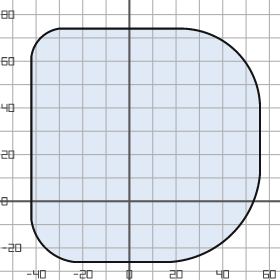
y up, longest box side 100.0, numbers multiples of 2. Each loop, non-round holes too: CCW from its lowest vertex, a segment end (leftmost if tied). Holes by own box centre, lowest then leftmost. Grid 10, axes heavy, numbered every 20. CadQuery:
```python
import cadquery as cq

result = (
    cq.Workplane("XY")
    .moveTo(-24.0, -26.0)
    .lineTo(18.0, -26.0)
    .threePointArc((44.0, -14.0), (56.0, 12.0))
    .lineTo(56.0, 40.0)
    .threePointArc((46.0, 64.0), (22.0, 74.0))
    .lineTo(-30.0, 74.0)
    .threePointArc((-38.0, 70.0), (-42.0, 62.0))
    .lineTo(-42.0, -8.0)
    .threePointArc((-36.0, -20.0), (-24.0, -26.0))
    .close()
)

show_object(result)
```